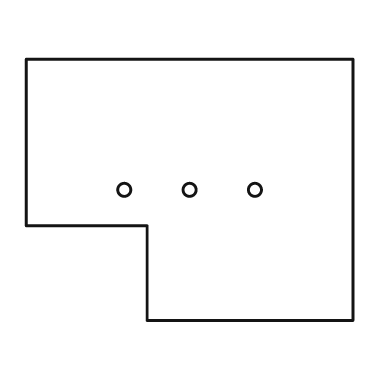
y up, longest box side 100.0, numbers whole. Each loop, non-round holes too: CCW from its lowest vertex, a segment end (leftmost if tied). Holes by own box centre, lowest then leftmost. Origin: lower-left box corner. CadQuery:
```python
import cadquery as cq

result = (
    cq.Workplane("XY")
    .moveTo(37.0, 0.0)
    .lineTo(100.0, 0.0)
    .lineTo(100.0, 80.0)
    .lineTo(0.0, 80.0)
    .lineTo(0.0, 29.0)
    .lineTo(37.0, 29.0)
    .close()
    .moveTo(30.0, 40.0)
    .circle(2.0)
    .moveTo(50.0, 40.0)
    .circle(2.0)
    .moveTo(70.0, 40.0)
    .circle(2.0)
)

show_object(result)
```